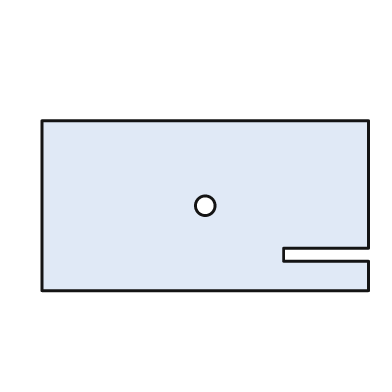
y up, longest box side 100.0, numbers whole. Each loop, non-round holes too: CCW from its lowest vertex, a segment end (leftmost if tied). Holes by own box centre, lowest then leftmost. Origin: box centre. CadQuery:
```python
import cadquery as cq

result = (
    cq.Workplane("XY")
    .moveTo(-50.0, -26.0)
    .lineTo(50.0, -26.0)
    .lineTo(50.0, -17.0)
    .lineTo(24.0, -17.0)
    .lineTo(24.0, -13.0)
    .lineTo(50.0, -13.0)
    .lineTo(50.0, 26.0)
    .lineTo(-50.0, 26.0)
    .close()
    .moveTo(0.0, 0.0)
    .circle(3.0)
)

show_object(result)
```